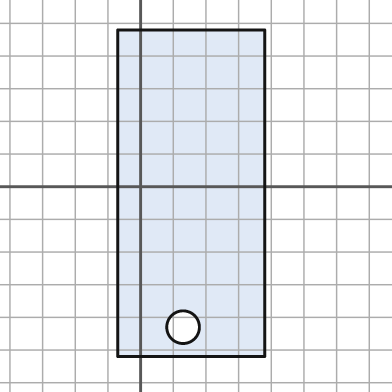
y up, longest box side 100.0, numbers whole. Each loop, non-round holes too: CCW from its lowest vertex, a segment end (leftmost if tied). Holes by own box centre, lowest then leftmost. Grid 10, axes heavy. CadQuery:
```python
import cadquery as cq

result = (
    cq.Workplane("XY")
    .moveTo(-7.0, -52.0)
    .lineTo(38.0, -52.0)
    .lineTo(38.0, 48.0)
    .lineTo(-7.0, 48.0)
    .close()
    .moveTo(13.0, -43.0)
    .circle(5.0)
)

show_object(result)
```